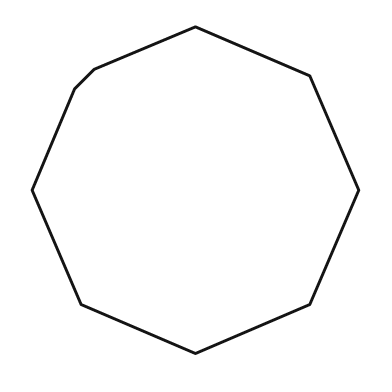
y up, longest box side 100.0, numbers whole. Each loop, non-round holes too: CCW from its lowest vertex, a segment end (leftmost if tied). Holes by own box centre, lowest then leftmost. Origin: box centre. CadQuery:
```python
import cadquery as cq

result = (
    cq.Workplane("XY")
    .moveTo(0.0, -50.0)
    .lineTo(35.0, -35.0)
    .lineTo(50.0, 0.0)
    .lineTo(35.0, 35.0)
    .lineTo(0.0, 50.0)
    .lineTo(-31.0, 37.0)
    .lineTo(-37.0, 31.0)
    .lineTo(-50.0, 0.0)
    .lineTo(-35.0, -35.0)
    .close()
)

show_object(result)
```